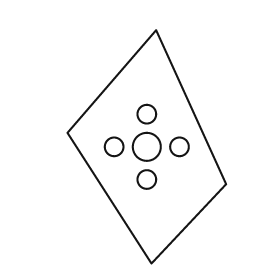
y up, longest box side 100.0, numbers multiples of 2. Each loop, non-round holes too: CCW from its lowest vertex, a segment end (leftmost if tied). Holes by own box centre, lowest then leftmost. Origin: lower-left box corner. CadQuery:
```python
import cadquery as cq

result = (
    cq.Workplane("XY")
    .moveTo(36.0, 0.0)
    .lineTo(68.0, 34.0)
    .lineTo(38.0, 100.0)
    .lineTo(0.0, 56.0)
    .close()
    .moveTo(34.0, 36.0)
    .circle(4.0)
    .moveTo(20.0, 50.0)
    .circle(4.0)
    .moveTo(34.0, 50.0)
    .circle(6.0)
    .moveTo(48.0, 50.0)
    .circle(4.0)
    .moveTo(34.0, 64.0)
    .circle(4.0)
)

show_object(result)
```